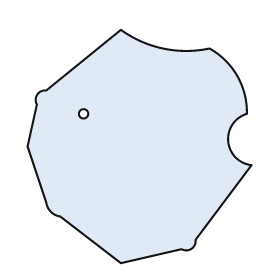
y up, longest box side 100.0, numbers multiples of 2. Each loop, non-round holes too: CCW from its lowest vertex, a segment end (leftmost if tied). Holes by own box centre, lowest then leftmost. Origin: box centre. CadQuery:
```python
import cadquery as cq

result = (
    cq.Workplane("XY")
    .moveTo(-8.0, -50.0)
    .lineTo(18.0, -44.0)
    .threePointArc((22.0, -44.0), (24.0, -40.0))
    .lineTo(48.0, -8.0)
    .threePointArc((38.0, 2.0), (46.0, 14.0))
    .threePointArc((42.0, 30.0), (30.0, 42.0))
    .threePointArc((10.0, 42.0), (-8.0, 50.0))
    .lineTo(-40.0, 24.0)
    .threePointArc((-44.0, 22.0), (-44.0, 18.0))
    .lineTo(-48.0, 0.0)
    .lineTo(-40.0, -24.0)
    .threePointArc((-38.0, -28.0), (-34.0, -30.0))
    .close()
    .moveTo(-24.0, 14.0)
    .circle(2.0)
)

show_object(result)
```